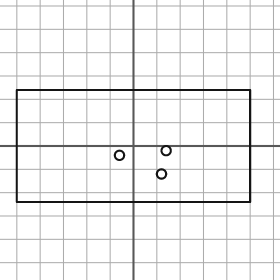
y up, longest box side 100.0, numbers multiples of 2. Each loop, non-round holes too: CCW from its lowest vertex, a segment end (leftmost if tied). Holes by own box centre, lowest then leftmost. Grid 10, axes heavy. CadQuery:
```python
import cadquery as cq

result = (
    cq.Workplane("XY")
    .moveTo(-50.0, -24.0)
    .lineTo(50.0, -24.0)
    .lineTo(50.0, 24.0)
    .lineTo(-50.0, 24.0)
    .close()
    .moveTo(12.0, -12.0)
    .circle(2.0)
    .moveTo(-6.0, -4.0)
    .circle(2.0)
    .moveTo(14.0, -2.0)
    .circle(2.0)
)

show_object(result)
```